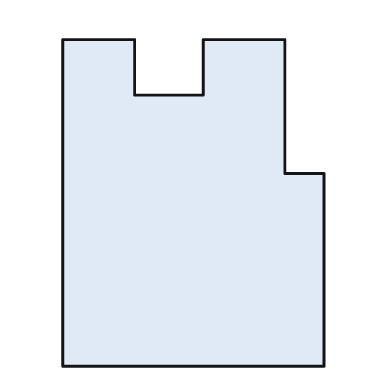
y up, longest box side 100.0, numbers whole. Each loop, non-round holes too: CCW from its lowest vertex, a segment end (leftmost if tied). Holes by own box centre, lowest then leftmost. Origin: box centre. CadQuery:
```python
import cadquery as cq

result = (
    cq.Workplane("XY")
    .moveTo(-40.0, -50.0)
    .lineTo(40.0, -50.0)
    .lineTo(40.0, 9.0)
    .lineTo(28.0, 9.0)
    .lineTo(28.0, 50.0)
    .lineTo(3.0, 50.0)
    .lineTo(3.0, 33.0)
    .lineTo(-18.0, 33.0)
    .lineTo(-18.0, 50.0)
    .lineTo(-40.0, 50.0)
    .close()
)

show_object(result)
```